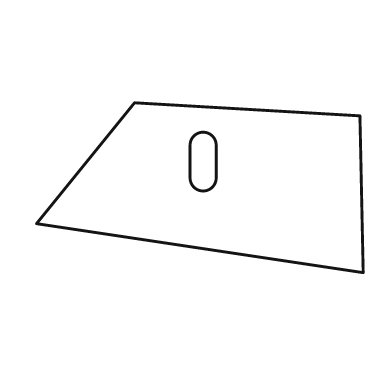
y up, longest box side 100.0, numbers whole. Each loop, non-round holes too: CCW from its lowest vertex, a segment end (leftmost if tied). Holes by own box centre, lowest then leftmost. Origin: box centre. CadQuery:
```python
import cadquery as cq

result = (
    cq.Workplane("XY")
    .moveTo(50.0, -26.0)
    .lineTo(49.0, 22.0)
    .lineTo(-20.0, 26.0)
    .lineTo(-50.0, -11.0)
    .close()
    .moveTo(-3.0, 3.0)
    .threePointArc((1.0, -1.0), (5.0, 3.0))
    .lineTo(5.0, 13.0)
    .threePointArc((1.0, 17.0), (-3.0, 13.0))
    .close()
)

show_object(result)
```